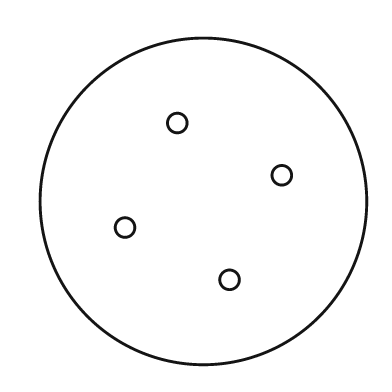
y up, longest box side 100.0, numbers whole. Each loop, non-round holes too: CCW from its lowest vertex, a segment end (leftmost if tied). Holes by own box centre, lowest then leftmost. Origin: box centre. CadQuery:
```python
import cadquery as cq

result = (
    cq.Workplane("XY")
    .moveTo(0.0, 0.0)
    .circle(50.0)
    .moveTo(8.0, -24.0)
    .circle(3.0)
    .moveTo(-24.0, -8.0)
    .circle(3.0)
    .moveTo(24.0, 8.0)
    .circle(3.0)
    .moveTo(-8.0, 24.0)
    .circle(3.0)
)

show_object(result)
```